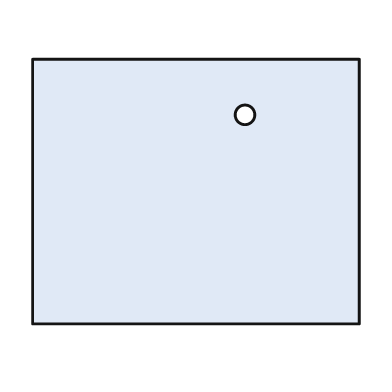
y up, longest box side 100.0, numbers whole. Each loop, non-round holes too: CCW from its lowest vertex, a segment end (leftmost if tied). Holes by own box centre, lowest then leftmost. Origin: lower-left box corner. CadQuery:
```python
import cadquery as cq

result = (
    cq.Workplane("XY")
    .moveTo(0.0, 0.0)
    .lineTo(100.0, 0.0)
    .lineTo(100.0, 81.0)
    .lineTo(0.0, 81.0)
    .close()
    .moveTo(65.0, 64.0)
    .circle(3.0)
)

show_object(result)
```